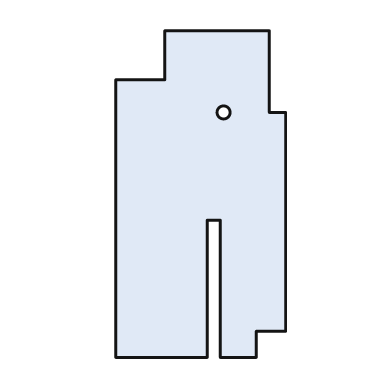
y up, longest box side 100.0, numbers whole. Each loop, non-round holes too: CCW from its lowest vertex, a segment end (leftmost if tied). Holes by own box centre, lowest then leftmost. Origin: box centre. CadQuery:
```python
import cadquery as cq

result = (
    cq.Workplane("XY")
    .moveTo(-26.0, -50.0)
    .lineTo(2.0, -50.0)
    .lineTo(2.0, -8.0)
    .lineTo(6.0, -8.0)
    .lineTo(6.0, -50.0)
    .lineTo(17.0, -50.0)
    .lineTo(17.0, -42.0)
    .lineTo(26.0, -42.0)
    .lineTo(26.0, 25.0)
    .lineTo(21.0, 25.0)
    .lineTo(21.0, 50.0)
    .lineTo(-11.0, 50.0)
    .lineTo(-11.0, 35.0)
    .lineTo(-26.0, 35.0)
    .close()
    .moveTo(7.0, 25.0)
    .circle(2.0)
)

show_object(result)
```